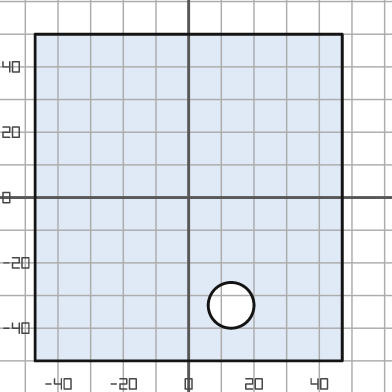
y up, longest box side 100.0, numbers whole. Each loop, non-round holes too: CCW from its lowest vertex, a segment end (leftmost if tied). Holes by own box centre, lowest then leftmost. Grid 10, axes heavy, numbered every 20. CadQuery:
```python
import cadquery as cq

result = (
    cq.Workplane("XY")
    .moveTo(-47.0, -50.0)
    .lineTo(47.0, -50.0)
    .lineTo(47.0, 50.0)
    .lineTo(-47.0, 50.0)
    .close()
    .moveTo(13.0, -33.0)
    .circle(7.0)
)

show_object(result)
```